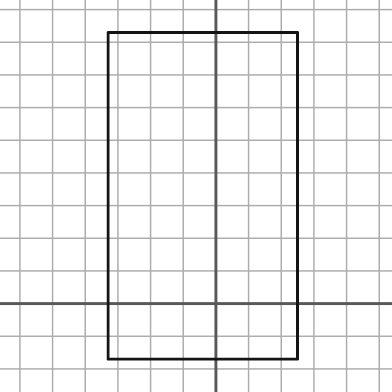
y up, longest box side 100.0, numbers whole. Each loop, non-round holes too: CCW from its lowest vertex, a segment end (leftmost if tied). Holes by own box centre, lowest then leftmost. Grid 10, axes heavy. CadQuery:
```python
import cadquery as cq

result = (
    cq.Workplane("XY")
    .moveTo(-33.0, -17.0)
    .lineTo(25.0, -17.0)
    .lineTo(25.0, 83.0)
    .lineTo(-33.0, 83.0)
    .close()
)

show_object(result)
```